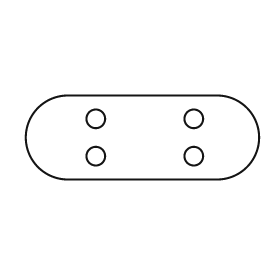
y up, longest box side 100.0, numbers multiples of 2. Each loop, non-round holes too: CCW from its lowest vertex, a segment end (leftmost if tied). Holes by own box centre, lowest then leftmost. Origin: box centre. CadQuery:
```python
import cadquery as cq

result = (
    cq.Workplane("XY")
    .moveTo(-32.0, -18.0)
    .lineTo(32.0, -18.0)
    .threePointArc((50.0, 0.0), (32.0, 18.0))
    .lineTo(-32.0, 18.0)
    .threePointArc((-50.0, 0.0), (-32.0, -18.0))
    .close()
    .moveTo(-20.0, -8.0)
    .circle(4.0)
    .moveTo(22.0, -8.0)
    .circle(4.0)
    .moveTo(-20.0, 8.0)
    .circle(4.0)
    .moveTo(22.0, 8.0)
    .circle(4.0)
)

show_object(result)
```